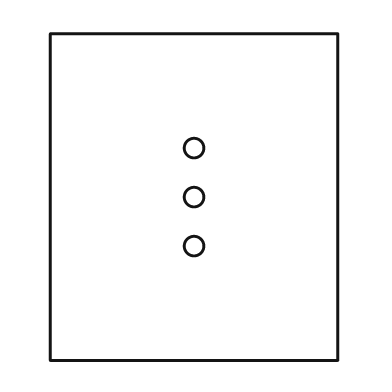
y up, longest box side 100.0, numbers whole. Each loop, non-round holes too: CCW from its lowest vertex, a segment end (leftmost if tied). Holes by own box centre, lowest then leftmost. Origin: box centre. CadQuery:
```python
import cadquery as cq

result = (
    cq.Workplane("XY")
    .moveTo(-44.0, -50.0)
    .lineTo(44.0, -50.0)
    .lineTo(44.0, 50.0)
    .lineTo(-44.0, 50.0)
    .close()
    .moveTo(0.0, -15.0)
    .circle(3.0)
    .moveTo(0.0, 0.0)
    .circle(3.0)
    .moveTo(0.0, 15.0)
    .circle(3.0)
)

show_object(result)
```